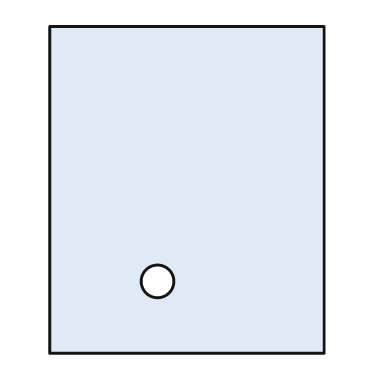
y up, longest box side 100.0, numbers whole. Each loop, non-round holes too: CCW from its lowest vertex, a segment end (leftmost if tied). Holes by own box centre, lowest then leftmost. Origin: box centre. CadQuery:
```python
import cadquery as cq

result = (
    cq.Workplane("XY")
    .moveTo(-42.0, -50.0)
    .lineTo(42.0, -50.0)
    .lineTo(42.0, 50.0)
    .lineTo(-42.0, 50.0)
    .close()
    .moveTo(-9.0, -28.0)
    .circle(5.0)
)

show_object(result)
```